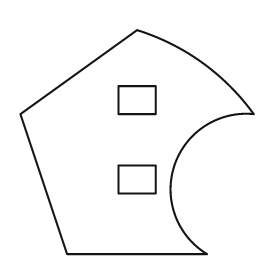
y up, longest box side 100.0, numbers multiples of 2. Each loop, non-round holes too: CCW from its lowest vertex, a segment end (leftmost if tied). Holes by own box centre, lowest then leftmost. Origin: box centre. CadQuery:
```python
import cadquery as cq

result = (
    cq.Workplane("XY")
    .moveTo(-30.0, -48.0)
    .lineTo(30.0, -48.0)
    .threePointArc((16.0, -10.0), (50.0, 12.0))
    .threePointArc((28.0, 34.0), (0.0, 48.0))
    .lineTo(-50.0, 12.0)
    .close()
    .moveTo(-8.0, -22.0)
    .lineTo(8.0, -22.0)
    .lineTo(8.0, -10.0)
    .lineTo(-8.0, -10.0)
    .close()
    .moveTo(-8.0, 12.0)
    .lineTo(8.0, 12.0)
    .lineTo(8.0, 24.0)
    .lineTo(-8.0, 24.0)
    .close()
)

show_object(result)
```